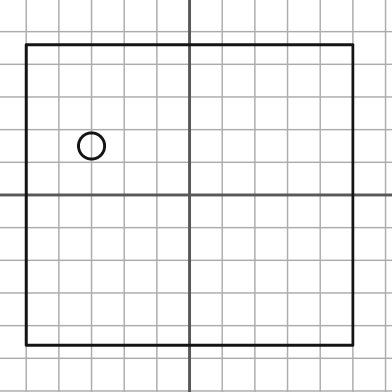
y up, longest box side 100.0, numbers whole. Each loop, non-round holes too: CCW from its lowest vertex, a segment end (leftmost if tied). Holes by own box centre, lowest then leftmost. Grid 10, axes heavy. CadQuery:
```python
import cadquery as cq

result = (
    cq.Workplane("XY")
    .moveTo(-50.0, -46.0)
    .lineTo(50.0, -46.0)
    .lineTo(50.0, 46.0)
    .lineTo(-50.0, 46.0)
    .close()
    .moveTo(-30.0, 15.0)
    .circle(4.0)
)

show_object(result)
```